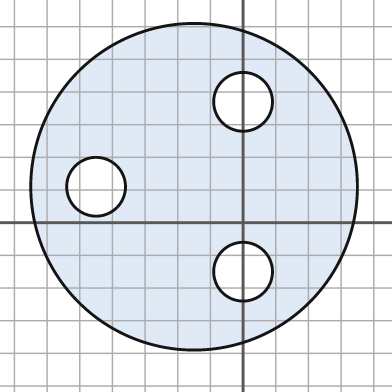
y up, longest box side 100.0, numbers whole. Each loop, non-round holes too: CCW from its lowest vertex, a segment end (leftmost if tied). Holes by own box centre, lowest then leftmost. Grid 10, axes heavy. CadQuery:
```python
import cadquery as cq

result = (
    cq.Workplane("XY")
    .moveTo(-15.0, 11.0)
    .circle(50.0)
    .moveTo(0.0, -15.0)
    .circle(9.0)
    .moveTo(-45.0, 11.0)
    .circle(9.0)
    .moveTo(0.0, 37.0)
    .circle(9.0)
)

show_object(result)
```